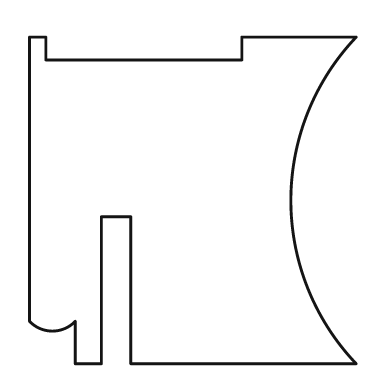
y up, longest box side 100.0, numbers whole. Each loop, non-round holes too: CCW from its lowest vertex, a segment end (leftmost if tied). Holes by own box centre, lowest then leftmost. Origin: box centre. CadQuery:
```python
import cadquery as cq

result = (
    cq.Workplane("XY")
    .moveTo(-36.0, -50.0)
    .lineTo(-28.0, -50.0)
    .lineTo(-28.0, -5.0)
    .lineTo(-19.0, -5.0)
    .lineTo(-19.0, -50.0)
    .lineTo(50.0, -50.0)
    .threePointArc((30.0, 0.0), (50.0, 50.0))
    .lineTo(15.0, 50.0)
    .lineTo(15.0, 43.0)
    .lineTo(-45.0, 43.0)
    .lineTo(-45.0, 50.0)
    .lineTo(-50.0, 50.0)
    .lineTo(-50.0, -37.0)
    .threePointArc((-43.0, -40.0), (-36.0, -37.0))
    .close()
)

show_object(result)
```